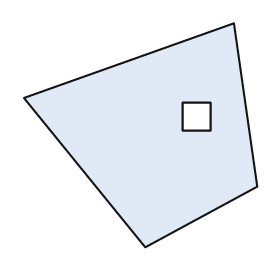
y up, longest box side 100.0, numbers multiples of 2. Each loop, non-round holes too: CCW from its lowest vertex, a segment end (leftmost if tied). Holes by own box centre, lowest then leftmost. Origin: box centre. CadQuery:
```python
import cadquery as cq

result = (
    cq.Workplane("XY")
    .moveTo(2.0, -48.0)
    .lineTo(50.0, -22.0)
    .lineTo(40.0, 48.0)
    .lineTo(-50.0, 16.0)
    .close()
    .moveTo(18.0, 2.0)
    .lineTo(30.0, 2.0)
    .lineTo(30.0, 14.0)
    .lineTo(18.0, 14.0)
    .close()
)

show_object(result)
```